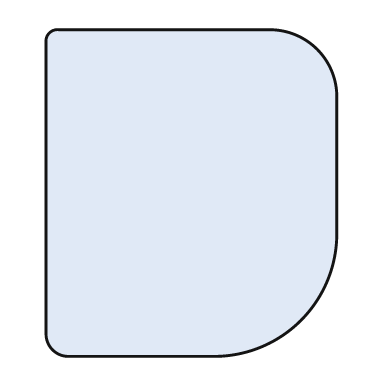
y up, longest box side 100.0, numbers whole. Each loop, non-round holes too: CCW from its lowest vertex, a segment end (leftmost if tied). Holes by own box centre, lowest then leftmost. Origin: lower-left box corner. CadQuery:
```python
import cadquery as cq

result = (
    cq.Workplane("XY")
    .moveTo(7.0, 0.0)
    .lineTo(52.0, 0.0)
    .threePointArc((78.0, 11.0), (89.0, 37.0))
    .lineTo(89.0, 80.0)
    .threePointArc((83.0, 94.0), (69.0, 100.0))
    .lineTo(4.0, 100.0)
    .threePointArc((1.0, 99.0), (0.0, 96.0))
    .lineTo(0.0, 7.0)
    .threePointArc((2.0, 2.0), (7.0, 0.0))
    .close()
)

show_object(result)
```